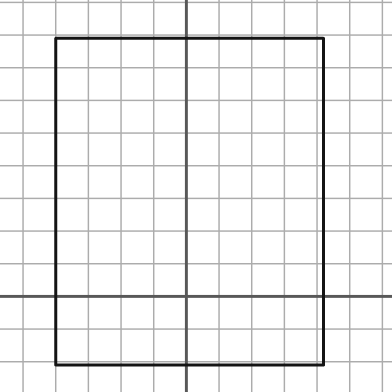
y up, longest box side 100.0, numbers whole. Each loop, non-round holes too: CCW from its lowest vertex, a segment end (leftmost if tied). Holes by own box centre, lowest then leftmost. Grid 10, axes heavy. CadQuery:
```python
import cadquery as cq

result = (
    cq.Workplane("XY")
    .moveTo(-40.0, -21.0)
    .lineTo(42.0, -21.0)
    .lineTo(42.0, 79.0)
    .lineTo(-40.0, 79.0)
    .close()
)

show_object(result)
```